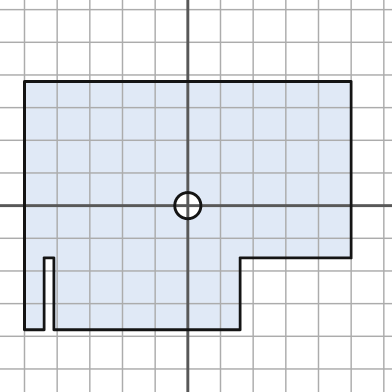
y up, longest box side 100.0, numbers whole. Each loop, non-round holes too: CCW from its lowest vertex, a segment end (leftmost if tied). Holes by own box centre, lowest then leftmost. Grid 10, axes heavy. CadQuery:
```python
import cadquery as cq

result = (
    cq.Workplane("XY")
    .moveTo(-50.0, -38.0)
    .lineTo(-44.0, -38.0)
    .lineTo(-44.0, -16.0)
    .lineTo(-41.0, -16.0)
    .lineTo(-41.0, -38.0)
    .lineTo(16.0, -38.0)
    .lineTo(16.0, -16.0)
    .lineTo(50.0, -16.0)
    .lineTo(50.0, 38.0)
    .lineTo(-50.0, 38.0)
    .close()
    .moveTo(0.0, 0.0)
    .circle(4.0)
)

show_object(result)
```